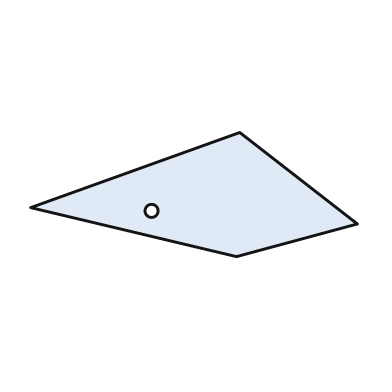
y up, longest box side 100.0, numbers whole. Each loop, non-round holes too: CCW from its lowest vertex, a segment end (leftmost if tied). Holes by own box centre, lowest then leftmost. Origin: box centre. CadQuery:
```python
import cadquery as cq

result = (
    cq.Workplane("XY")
    .moveTo(13.0, -19.0)
    .lineTo(50.0, -9.0)
    .lineTo(14.0, 19.0)
    .lineTo(-50.0, -4.0)
    .close()
    .moveTo(-13.0, -5.0)
    .circle(2.0)
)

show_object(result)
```